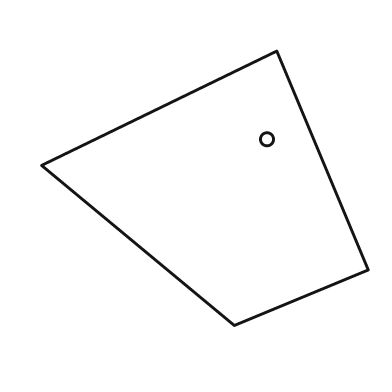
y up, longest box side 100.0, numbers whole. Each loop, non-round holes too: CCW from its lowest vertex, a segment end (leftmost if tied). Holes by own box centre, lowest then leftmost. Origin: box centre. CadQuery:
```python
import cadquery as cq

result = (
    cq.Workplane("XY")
    .moveTo(9.0, -42.0)
    .lineTo(50.0, -25.0)
    .lineTo(22.0, 42.0)
    .lineTo(-50.0, 7.0)
    .close()
    .moveTo(19.0, 15.0)
    .circle(2.0)
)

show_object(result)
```